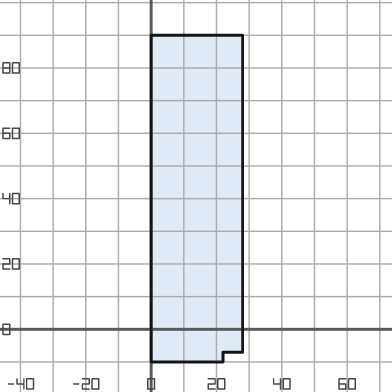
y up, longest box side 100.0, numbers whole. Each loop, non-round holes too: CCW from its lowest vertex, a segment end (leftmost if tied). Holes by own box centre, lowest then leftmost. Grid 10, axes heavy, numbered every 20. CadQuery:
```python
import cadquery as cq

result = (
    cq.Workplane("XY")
    .moveTo(0.0, -10.0)
    .lineTo(22.0, -10.0)
    .lineTo(22.0, -7.0)
    .lineTo(28.0, -7.0)
    .lineTo(28.0, 90.0)
    .lineTo(0.0, 90.0)
    .close()
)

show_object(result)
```